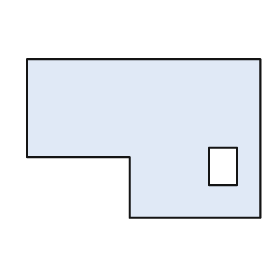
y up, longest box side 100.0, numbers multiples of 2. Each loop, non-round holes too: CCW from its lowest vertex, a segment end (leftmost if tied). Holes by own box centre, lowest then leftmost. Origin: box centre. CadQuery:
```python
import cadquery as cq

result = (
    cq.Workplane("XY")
    .moveTo(-6.0, -34.0)
    .lineTo(50.0, -34.0)
    .lineTo(50.0, 34.0)
    .lineTo(-50.0, 34.0)
    .lineTo(-50.0, -8.0)
    .lineTo(-6.0, -8.0)
    .close()
    .moveTo(28.0, -20.0)
    .lineTo(40.0, -20.0)
    .lineTo(40.0, -4.0)
    .lineTo(28.0, -4.0)
    .close()
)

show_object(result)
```